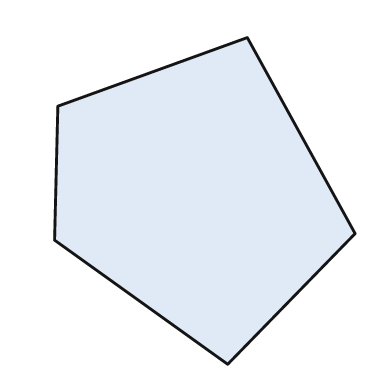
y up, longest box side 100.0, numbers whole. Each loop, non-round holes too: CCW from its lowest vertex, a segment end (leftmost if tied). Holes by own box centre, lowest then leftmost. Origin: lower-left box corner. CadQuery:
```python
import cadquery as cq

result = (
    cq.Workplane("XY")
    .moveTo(53.0, 0.0)
    .lineTo(92.0, 40.0)
    .lineTo(59.0, 100.0)
    .lineTo(1.0, 79.0)
    .lineTo(0.0, 38.0)
    .close()
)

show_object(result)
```